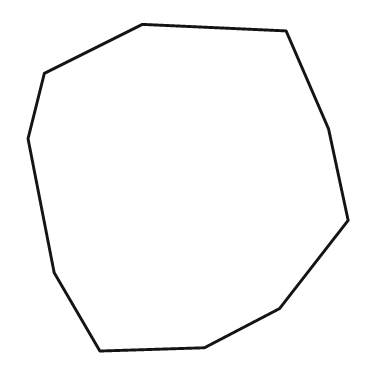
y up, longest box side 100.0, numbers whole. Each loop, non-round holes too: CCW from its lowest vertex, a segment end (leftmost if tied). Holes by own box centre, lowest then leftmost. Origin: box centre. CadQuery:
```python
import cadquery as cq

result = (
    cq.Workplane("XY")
    .moveTo(-27.0, -50.0)
    .lineTo(5.0, -49.0)
    .lineTo(28.0, -37.0)
    .lineTo(49.0, -10.0)
    .lineTo(43.0, 18.0)
    .lineTo(30.0, 48.0)
    .lineTo(-14.0, 50.0)
    .lineTo(-44.0, 35.0)
    .lineTo(-49.0, 15.0)
    .lineTo(-41.0, -26.0)
    .close()
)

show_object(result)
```